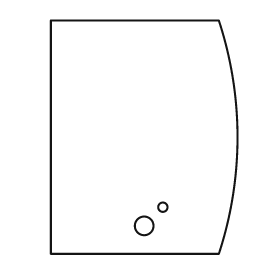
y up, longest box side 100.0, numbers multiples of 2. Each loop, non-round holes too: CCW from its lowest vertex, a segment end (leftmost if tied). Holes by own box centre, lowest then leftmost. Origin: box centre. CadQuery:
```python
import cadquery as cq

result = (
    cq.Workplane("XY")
    .moveTo(-40.0, -50.0)
    .lineTo(32.0, -50.0)
    .threePointArc((40.0, 0.0), (32.0, 50.0))
    .lineTo(-40.0, 50.0)
    .close()
    .moveTo(0.0, -38.0)
    .circle(4.0)
    .moveTo(8.0, -30.0)
    .circle(2.0)
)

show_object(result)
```